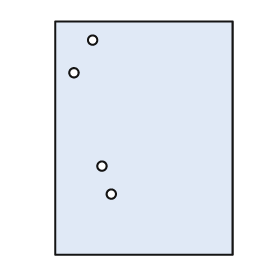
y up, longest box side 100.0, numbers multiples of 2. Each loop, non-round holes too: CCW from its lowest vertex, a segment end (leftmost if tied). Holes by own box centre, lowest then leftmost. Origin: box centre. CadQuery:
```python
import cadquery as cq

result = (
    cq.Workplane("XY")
    .moveTo(-38.0, -50.0)
    .lineTo(38.0, -50.0)
    .lineTo(38.0, 50.0)
    .lineTo(-38.0, 50.0)
    .close()
    .moveTo(-14.0, -24.0)
    .circle(2.0)
    .moveTo(-18.0, -12.0)
    .circle(2.0)
    .moveTo(-30.0, 28.0)
    .circle(2.0)
    .moveTo(-22.0, 42.0)
    .circle(2.0)
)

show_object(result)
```